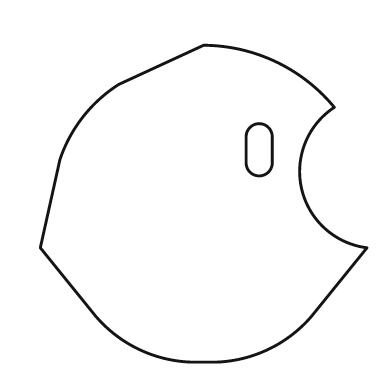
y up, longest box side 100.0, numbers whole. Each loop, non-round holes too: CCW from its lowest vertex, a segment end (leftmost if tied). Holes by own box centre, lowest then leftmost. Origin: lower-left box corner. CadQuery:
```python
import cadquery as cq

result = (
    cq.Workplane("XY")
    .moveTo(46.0, 0.0)
    .lineTo(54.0, 0.0)
    .threePointArc((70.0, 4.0), (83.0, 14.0))
    .lineTo(100.0, 35.0)
    .threePointArc((80.0, 53.0), (90.0, 78.0))
    .threePointArc((72.0, 92.0), (50.0, 97.0))
    .lineTo(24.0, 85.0)
    .threePointArc((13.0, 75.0), (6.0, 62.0))
    .lineTo(0.0, 35.0)
    .lineTo(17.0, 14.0)
    .threePointArc((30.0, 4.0), (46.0, 0.0))
    .close()
    .moveTo(63.0, 61.0)
    .threePointArc((67.0, 57.0), (71.0, 61.0))
    .lineTo(71.0, 69.0)
    .threePointArc((67.0, 73.0), (63.0, 69.0))
    .close()
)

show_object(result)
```